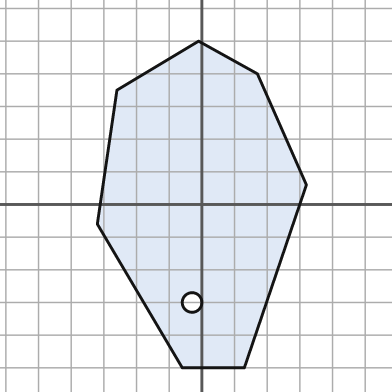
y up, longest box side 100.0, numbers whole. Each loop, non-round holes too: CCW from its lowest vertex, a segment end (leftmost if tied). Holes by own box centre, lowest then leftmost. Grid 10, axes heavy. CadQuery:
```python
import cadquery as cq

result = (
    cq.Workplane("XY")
    .moveTo(-6.0, -50.0)
    .lineTo(13.0, -50.0)
    .lineTo(32.0, 6.0)
    .lineTo(17.0, 40.0)
    .lineTo(-1.0, 50.0)
    .lineTo(-26.0, 35.0)
    .lineTo(-32.0, -6.0)
    .close()
    .moveTo(-3.0, -30.0)
    .circle(3.0)
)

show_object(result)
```